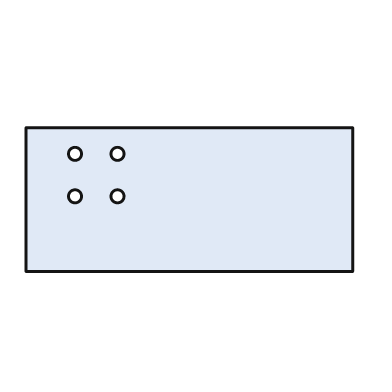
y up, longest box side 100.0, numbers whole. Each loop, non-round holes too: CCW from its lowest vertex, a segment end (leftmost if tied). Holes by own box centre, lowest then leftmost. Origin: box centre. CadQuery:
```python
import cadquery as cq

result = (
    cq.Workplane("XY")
    .moveTo(-50.0, -22.0)
    .lineTo(50.0, -22.0)
    .lineTo(50.0, 22.0)
    .lineTo(-50.0, 22.0)
    .close()
    .moveTo(-35.0, 1.0)
    .circle(2.0)
    .moveTo(-22.0, 1.0)
    .circle(2.0)
    .moveTo(-35.0, 14.0)
    .circle(2.0)
    .moveTo(-22.0, 14.0)
    .circle(2.0)
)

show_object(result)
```